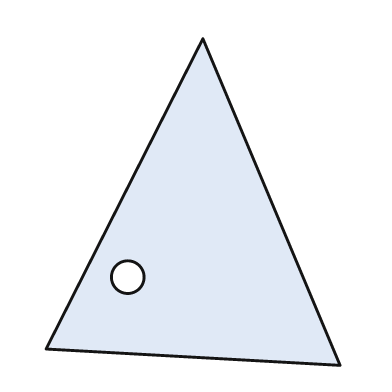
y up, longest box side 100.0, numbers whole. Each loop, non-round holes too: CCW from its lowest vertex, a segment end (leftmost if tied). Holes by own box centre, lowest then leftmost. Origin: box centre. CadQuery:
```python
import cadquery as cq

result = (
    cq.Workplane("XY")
    .moveTo(45.0, -50.0)
    .lineTo(3.0, 50.0)
    .lineTo(-45.0, -45.0)
    .close()
    .moveTo(-20.0, -23.0)
    .circle(5.0)
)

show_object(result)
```